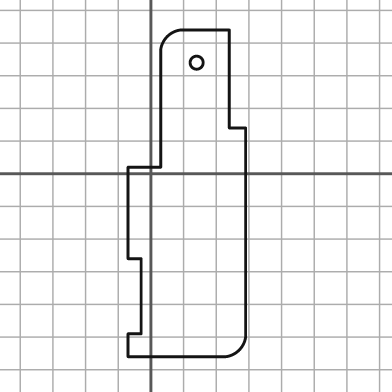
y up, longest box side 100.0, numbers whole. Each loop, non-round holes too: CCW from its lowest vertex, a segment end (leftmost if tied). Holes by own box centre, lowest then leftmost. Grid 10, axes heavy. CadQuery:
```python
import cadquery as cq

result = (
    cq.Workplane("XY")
    .moveTo(-7.0, -56.0)
    .lineTo(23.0, -56.0)
    .threePointArc((27.0, -54.0), (29.0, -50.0))
    .lineTo(29.0, 14.0)
    .lineTo(24.0, 14.0)
    .lineTo(24.0, 44.0)
    .lineTo(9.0, 44.0)
    .threePointArc((5.0, 42.0), (3.0, 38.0))
    .lineTo(3.0, 2.0)
    .lineTo(-7.0, 2.0)
    .lineTo(-7.0, -26.0)
    .lineTo(-3.0, -26.0)
    .lineTo(-3.0, -49.0)
    .lineTo(-7.0, -49.0)
    .close()
    .moveTo(14.0, 34.0)
    .circle(2.0)
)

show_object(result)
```